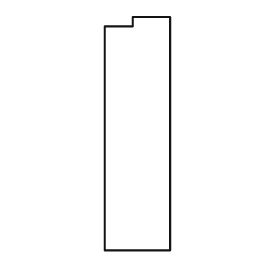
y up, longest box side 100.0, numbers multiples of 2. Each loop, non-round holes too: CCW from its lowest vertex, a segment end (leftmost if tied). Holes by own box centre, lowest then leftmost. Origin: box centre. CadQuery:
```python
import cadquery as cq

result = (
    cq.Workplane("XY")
    .moveTo(-14.0, -50.0)
    .lineTo(14.0, -50.0)
    .lineTo(14.0, 50.0)
    .lineTo(-2.0, 50.0)
    .lineTo(-2.0, 46.0)
    .lineTo(-14.0, 46.0)
    .close()
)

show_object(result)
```